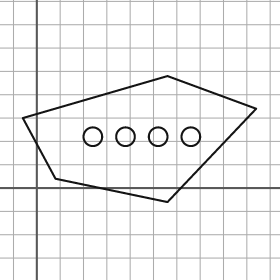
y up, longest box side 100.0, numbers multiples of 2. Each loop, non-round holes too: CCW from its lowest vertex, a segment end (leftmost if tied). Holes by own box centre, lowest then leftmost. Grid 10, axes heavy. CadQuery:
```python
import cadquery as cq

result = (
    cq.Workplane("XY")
    .moveTo(56.0, -6.0)
    .lineTo(94.0, 34.0)
    .lineTo(56.0, 48.0)
    .lineTo(-6.0, 30.0)
    .lineTo(8.0, 4.0)
    .close()
    .moveTo(24.0, 22.0)
    .circle(4.0)
    .moveTo(38.0, 22.0)
    .circle(4.0)
    .moveTo(52.0, 22.0)
    .circle(4.0)
    .moveTo(66.0, 22.0)
    .circle(4.0)
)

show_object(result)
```